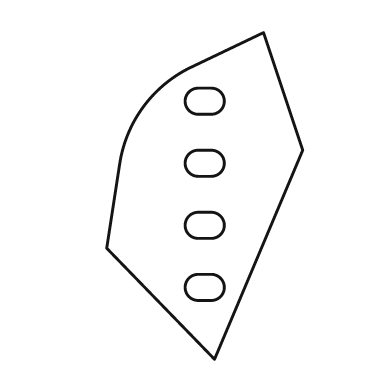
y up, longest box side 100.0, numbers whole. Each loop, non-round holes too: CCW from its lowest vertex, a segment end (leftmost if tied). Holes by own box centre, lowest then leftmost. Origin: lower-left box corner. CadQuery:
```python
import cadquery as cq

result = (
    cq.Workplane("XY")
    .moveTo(33.0, 0.0)
    .lineTo(60.0, 64.0)
    .lineTo(48.0, 100.0)
    .lineTo(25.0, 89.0)
    .threePointArc((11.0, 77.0), (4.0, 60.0))
    .lineTo(0.0, 34.0)
    .close()
    .moveTo(28.0, 18.0)
    .lineTo(32.0, 18.0)
    .threePointArc((36.0, 22.0), (32.0, 26.0))
    .lineTo(28.0, 26.0)
    .threePointArc((24.0, 22.0), (28.0, 18.0))
    .close()
    .moveTo(28.0, 37.0)
    .lineTo(32.0, 37.0)
    .threePointArc((36.0, 41.0), (32.0, 45.0))
    .lineTo(28.0, 45.0)
    .threePointArc((24.0, 41.0), (28.0, 37.0))
    .close()
    .moveTo(28.0, 56.0)
    .lineTo(32.0, 56.0)
    .threePointArc((36.0, 60.0), (32.0, 64.0))
    .lineTo(28.0, 64.0)
    .threePointArc((24.0, 60.0), (28.0, 56.0))
    .close()
    .moveTo(28.0, 75.0)
    .lineTo(32.0, 75.0)
    .threePointArc((36.0, 79.0), (32.0, 83.0))
    .lineTo(28.0, 83.0)
    .threePointArc((24.0, 79.0), (28.0, 75.0))
    .close()
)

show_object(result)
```